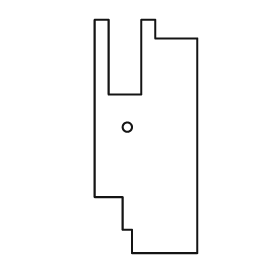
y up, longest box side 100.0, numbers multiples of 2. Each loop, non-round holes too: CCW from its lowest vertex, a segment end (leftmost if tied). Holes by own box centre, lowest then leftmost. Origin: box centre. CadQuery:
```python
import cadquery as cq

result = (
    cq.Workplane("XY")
    .moveTo(-6.0, -50.0)
    .lineTo(22.0, -50.0)
    .lineTo(22.0, 42.0)
    .lineTo(4.0, 42.0)
    .lineTo(4.0, 50.0)
    .lineTo(-2.0, 50.0)
    .lineTo(-2.0, 18.0)
    .lineTo(-16.0, 18.0)
    .lineTo(-16.0, 50.0)
    .lineTo(-22.0, 50.0)
    .lineTo(-22.0, -26.0)
    .lineTo(-10.0, -26.0)
    .lineTo(-10.0, -40.0)
    .lineTo(-6.0, -40.0)
    .close()
    .moveTo(-8.0, 4.0)
    .circle(2.0)
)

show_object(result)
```